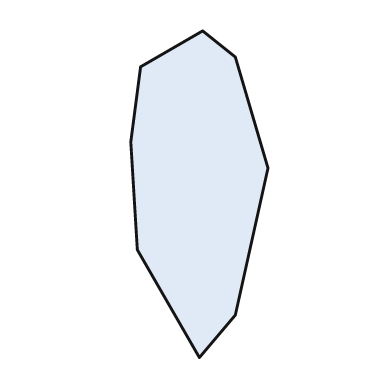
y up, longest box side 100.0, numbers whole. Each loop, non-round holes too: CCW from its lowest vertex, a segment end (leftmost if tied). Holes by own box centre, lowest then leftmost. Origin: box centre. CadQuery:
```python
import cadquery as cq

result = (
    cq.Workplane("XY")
    .moveTo(0.0, -50.0)
    .lineTo(11.0, -37.0)
    .lineTo(21.0, 8.0)
    .lineTo(11.0, 42.0)
    .lineTo(1.0, 50.0)
    .lineTo(-18.0, 39.0)
    .lineTo(-21.0, 16.0)
    .lineTo(-19.0, -17.0)
    .close()
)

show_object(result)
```